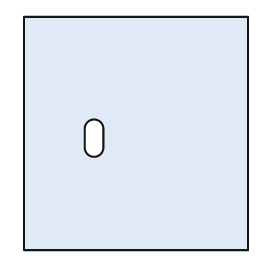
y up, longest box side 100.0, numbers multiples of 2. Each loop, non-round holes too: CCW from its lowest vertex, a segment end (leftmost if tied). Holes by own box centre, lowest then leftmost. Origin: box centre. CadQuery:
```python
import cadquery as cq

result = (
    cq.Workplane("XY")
    .moveTo(-48.0, -50.0)
    .lineTo(48.0, -50.0)
    .lineTo(48.0, 50.0)
    .lineTo(-48.0, 50.0)
    .close()
    .moveTo(-22.0, -6.0)
    .threePointArc((-18.0, -10.0), (-14.0, -6.0))
    .lineTo(-14.0, 2.0)
    .threePointArc((-18.0, 6.0), (-22.0, 2.0))
    .close()
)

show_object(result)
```